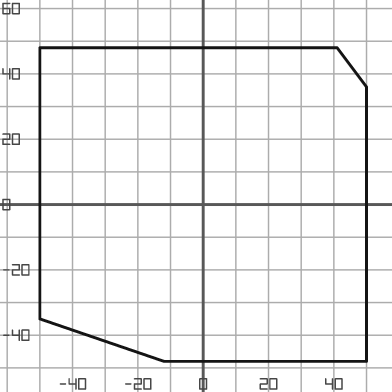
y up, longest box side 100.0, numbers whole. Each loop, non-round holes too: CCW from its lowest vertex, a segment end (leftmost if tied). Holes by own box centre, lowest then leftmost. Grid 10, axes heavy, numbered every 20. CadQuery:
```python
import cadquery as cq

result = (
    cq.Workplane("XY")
    .moveTo(-12.0, -48.0)
    .lineTo(50.0, -48.0)
    .lineTo(50.0, 36.0)
    .lineTo(41.0, 48.0)
    .lineTo(-50.0, 48.0)
    .lineTo(-50.0, -35.0)
    .close()
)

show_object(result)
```